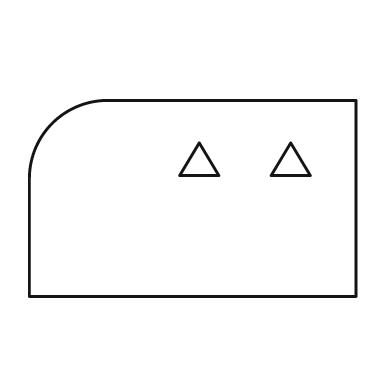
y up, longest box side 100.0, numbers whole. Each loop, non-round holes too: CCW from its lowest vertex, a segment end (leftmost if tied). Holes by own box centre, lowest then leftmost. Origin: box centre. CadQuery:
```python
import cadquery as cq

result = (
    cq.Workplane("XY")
    .moveTo(-50.0, -30.0)
    .lineTo(50.0, -30.0)
    .lineTo(50.0, 30.0)
    .lineTo(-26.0, 30.0)
    .threePointArc((-43.0, 23.0), (-50.0, 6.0))
    .close()
    .moveTo(-4.0, 7.0)
    .lineTo(8.0, 7.0)
    .lineTo(2.0, 17.0)
    .close()
    .moveTo(24.0, 7.0)
    .lineTo(36.0, 7.0)
    .lineTo(30.0, 17.0)
    .close()
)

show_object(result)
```